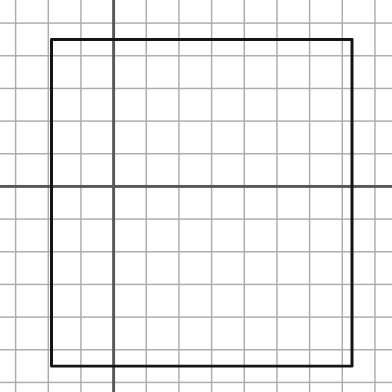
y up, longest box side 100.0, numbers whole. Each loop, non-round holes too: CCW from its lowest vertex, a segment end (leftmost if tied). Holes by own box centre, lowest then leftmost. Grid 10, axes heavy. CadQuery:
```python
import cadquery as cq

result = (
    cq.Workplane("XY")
    .moveTo(-19.0, -55.0)
    .lineTo(73.0, -55.0)
    .lineTo(73.0, 45.0)
    .lineTo(-19.0, 45.0)
    .close()
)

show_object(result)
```